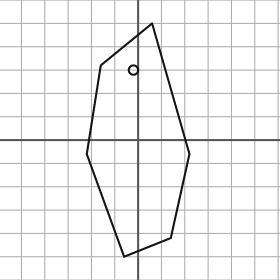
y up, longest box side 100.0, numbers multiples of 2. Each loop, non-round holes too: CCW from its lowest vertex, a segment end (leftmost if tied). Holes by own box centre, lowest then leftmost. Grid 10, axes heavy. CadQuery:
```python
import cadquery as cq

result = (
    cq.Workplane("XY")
    .moveTo(-6.0, -50.0)
    .lineTo(14.0, -42.0)
    .lineTo(22.0, -6.0)
    .lineTo(6.0, 50.0)
    .lineTo(-16.0, 32.0)
    .lineTo(-22.0, -6.0)
    .close()
    .moveTo(-2.0, 30.0)
    .circle(2.0)
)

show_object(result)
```